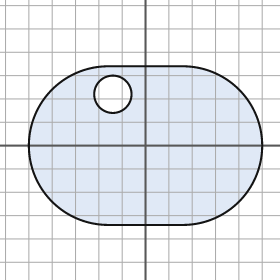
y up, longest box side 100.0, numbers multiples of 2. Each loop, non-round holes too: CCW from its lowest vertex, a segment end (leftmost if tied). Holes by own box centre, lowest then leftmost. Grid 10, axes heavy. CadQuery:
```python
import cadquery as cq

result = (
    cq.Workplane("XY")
    .moveTo(-16.0, -34.0)
    .lineTo(16.0, -34.0)
    .threePointArc((50.0, 0.0), (16.0, 34.0))
    .lineTo(-16.0, 34.0)
    .threePointArc((-50.0, 0.0), (-16.0, -34.0))
    .close()
    .moveTo(-14.0, 22.0)
    .circle(8.0)
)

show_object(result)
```